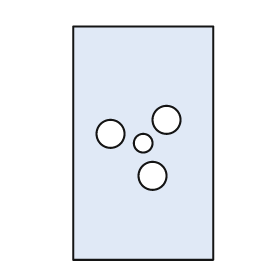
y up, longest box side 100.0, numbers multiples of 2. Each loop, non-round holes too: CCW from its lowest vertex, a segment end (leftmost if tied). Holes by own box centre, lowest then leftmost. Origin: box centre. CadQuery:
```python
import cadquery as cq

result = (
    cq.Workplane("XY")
    .moveTo(-30.0, -50.0)
    .lineTo(30.0, -50.0)
    .lineTo(30.0, 50.0)
    .lineTo(-30.0, 50.0)
    .close()
    .moveTo(4.0, -14.0)
    .circle(6.0)
    .moveTo(0.0, 0.0)
    .circle(4.0)
    .moveTo(-14.0, 4.0)
    .circle(6.0)
    .moveTo(10.0, 10.0)
    .circle(6.0)
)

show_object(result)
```